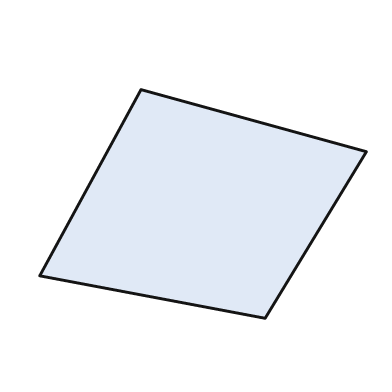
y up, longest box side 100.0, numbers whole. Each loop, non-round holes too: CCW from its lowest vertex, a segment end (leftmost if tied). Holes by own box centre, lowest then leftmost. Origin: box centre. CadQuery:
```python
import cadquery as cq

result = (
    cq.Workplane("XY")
    .moveTo(19.0, -35.0)
    .lineTo(50.0, 16.0)
    .lineTo(-19.0, 35.0)
    .lineTo(-50.0, -22.0)
    .close()
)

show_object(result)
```